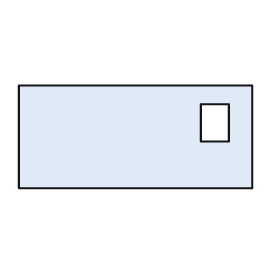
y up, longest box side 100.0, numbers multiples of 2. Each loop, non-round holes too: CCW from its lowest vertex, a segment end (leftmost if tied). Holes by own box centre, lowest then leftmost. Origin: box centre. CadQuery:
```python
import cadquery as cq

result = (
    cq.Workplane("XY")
    .moveTo(-50.0, -22.0)
    .lineTo(50.0, -22.0)
    .lineTo(50.0, 22.0)
    .lineTo(-50.0, 22.0)
    .close()
    .moveTo(28.0, -2.0)
    .lineTo(40.0, -2.0)
    .lineTo(40.0, 14.0)
    .lineTo(28.0, 14.0)
    .close()
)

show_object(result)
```